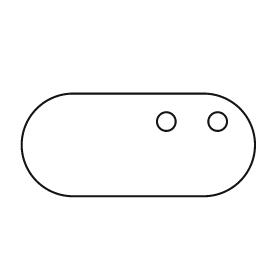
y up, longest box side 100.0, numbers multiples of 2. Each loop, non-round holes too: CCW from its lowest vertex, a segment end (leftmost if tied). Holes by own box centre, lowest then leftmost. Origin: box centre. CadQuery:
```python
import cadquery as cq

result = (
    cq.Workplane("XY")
    .moveTo(-28.0, -22.0)
    .lineTo(28.0, -22.0)
    .threePointArc((50.0, 0.0), (28.0, 22.0))
    .lineTo(-28.0, 22.0)
    .threePointArc((-50.0, 0.0), (-28.0, -22.0))
    .close()
    .moveTo(12.0, 10.0)
    .circle(4.0)
    .moveTo(34.0, 10.0)
    .circle(4.0)
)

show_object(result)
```